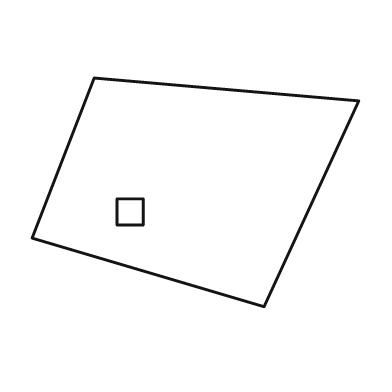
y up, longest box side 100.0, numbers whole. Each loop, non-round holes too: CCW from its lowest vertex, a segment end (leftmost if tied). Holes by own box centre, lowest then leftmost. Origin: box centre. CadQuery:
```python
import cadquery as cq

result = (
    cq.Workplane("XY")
    .moveTo(21.0, -35.0)
    .lineTo(50.0, 28.0)
    .lineTo(-31.0, 35.0)
    .lineTo(-50.0, -14.0)
    .close()
    .moveTo(-24.0, -10.0)
    .lineTo(-16.0, -10.0)
    .lineTo(-16.0, -2.0)
    .lineTo(-24.0, -2.0)
    .close()
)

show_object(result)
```